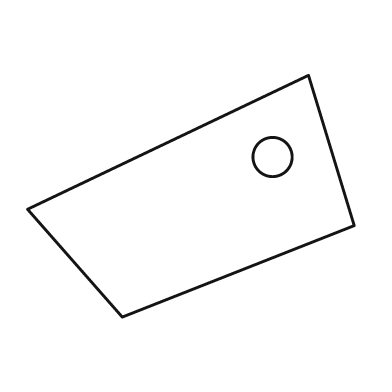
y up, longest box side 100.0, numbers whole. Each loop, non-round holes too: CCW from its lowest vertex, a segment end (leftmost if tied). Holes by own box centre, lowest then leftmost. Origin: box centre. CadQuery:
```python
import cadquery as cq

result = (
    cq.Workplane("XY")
    .moveTo(-21.0, -37.0)
    .lineTo(50.0, -9.0)
    .lineTo(36.0, 37.0)
    .lineTo(-50.0, -4.0)
    .close()
    .moveTo(25.0, 12.0)
    .circle(6.0)
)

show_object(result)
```